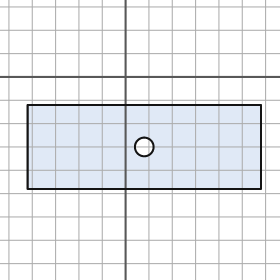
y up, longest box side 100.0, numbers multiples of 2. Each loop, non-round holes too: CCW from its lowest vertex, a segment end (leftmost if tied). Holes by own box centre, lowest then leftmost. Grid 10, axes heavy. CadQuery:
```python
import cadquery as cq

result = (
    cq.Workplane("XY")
    .moveTo(-42.0, -48.0)
    .lineTo(58.0, -48.0)
    .lineTo(58.0, -12.0)
    .lineTo(-42.0, -12.0)
    .close()
    .moveTo(8.0, -30.0)
    .circle(4.0)
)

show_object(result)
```